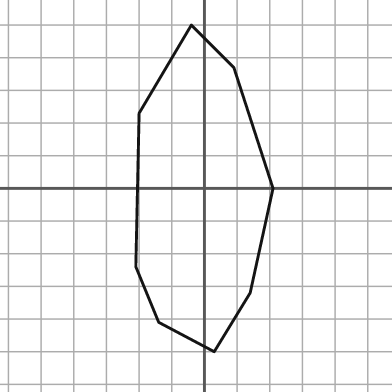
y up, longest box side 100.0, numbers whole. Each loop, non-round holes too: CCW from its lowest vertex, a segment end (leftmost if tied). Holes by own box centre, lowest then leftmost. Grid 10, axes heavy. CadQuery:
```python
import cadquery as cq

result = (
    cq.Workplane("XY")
    .moveTo(3.0, -50.0)
    .lineTo(14.0, -32.0)
    .lineTo(21.0, 0.0)
    .lineTo(9.0, 37.0)
    .lineTo(-4.0, 50.0)
    .lineTo(-20.0, 23.0)
    .lineTo(-21.0, -24.0)
    .lineTo(-14.0, -41.0)
    .close()
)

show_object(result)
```